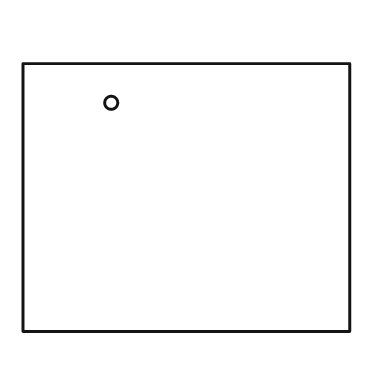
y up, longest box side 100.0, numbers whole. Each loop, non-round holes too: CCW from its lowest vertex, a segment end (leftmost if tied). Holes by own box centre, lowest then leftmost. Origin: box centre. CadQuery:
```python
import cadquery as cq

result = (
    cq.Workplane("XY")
    .moveTo(-50.0, -41.0)
    .lineTo(50.0, -41.0)
    .lineTo(50.0, 41.0)
    .lineTo(-50.0, 41.0)
    .close()
    .moveTo(-23.0, 29.0)
    .circle(2.0)
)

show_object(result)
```